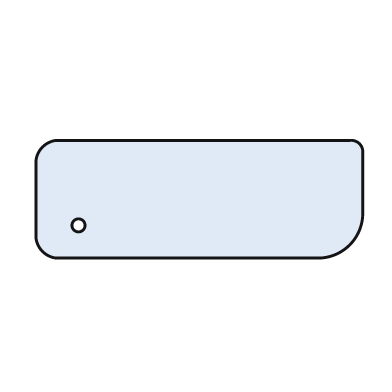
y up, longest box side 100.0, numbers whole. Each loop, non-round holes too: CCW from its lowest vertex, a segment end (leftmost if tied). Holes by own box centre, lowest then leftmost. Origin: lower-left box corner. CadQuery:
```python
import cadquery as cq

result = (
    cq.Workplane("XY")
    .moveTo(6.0, 0.0)
    .lineTo(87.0, 0.0)
    .threePointArc((96.0, 4.0), (100.0, 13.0))
    .lineTo(100.0, 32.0)
    .threePointArc((99.0, 35.0), (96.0, 36.0))
    .lineTo(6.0, 36.0)
    .threePointArc((2.0, 34.0), (0.0, 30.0))
    .lineTo(0.0, 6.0)
    .threePointArc((2.0, 2.0), (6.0, 0.0))
    .close()
    .moveTo(13.0, 10.0)
    .circle(2.0)
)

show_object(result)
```